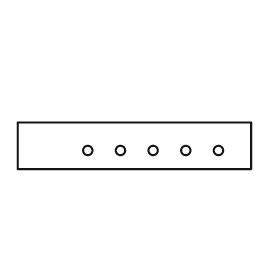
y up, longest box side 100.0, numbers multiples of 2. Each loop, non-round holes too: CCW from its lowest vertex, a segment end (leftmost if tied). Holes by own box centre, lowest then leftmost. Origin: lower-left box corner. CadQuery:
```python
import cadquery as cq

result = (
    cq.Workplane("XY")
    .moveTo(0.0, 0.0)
    .lineTo(100.0, 0.0)
    .lineTo(100.0, 20.0)
    .lineTo(0.0, 20.0)
    .close()
    .moveTo(30.0, 8.0)
    .circle(2.0)
    .moveTo(44.0, 8.0)
    .circle(2.0)
    .moveTo(58.0, 8.0)
    .circle(2.0)
    .moveTo(72.0, 8.0)
    .circle(2.0)
    .moveTo(86.0, 8.0)
    .circle(2.0)
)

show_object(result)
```